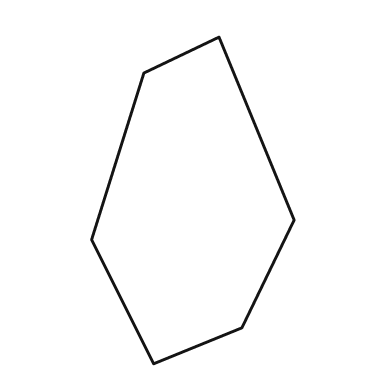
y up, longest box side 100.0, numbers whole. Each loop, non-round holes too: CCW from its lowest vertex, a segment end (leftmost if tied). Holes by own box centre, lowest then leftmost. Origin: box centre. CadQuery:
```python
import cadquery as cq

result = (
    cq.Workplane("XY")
    .moveTo(-12.0, -50.0)
    .lineTo(15.0, -39.0)
    .lineTo(31.0, -6.0)
    .lineTo(8.0, 50.0)
    .lineTo(-15.0, 39.0)
    .lineTo(-31.0, -12.0)
    .close()
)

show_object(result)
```